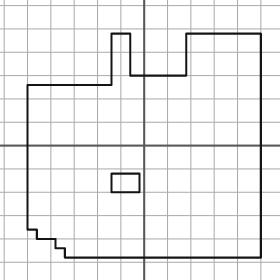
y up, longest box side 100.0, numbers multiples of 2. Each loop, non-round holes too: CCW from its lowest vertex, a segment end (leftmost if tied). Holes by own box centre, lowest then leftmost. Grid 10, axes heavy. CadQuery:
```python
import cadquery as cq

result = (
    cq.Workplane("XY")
    .moveTo(-34.0, -48.0)
    .lineTo(50.0, -48.0)
    .lineTo(50.0, 48.0)
    .lineTo(18.0, 48.0)
    .lineTo(18.0, 30.0)
    .lineTo(-6.0, 30.0)
    .lineTo(-6.0, 48.0)
    .lineTo(-14.0, 48.0)
    .lineTo(-14.0, 26.0)
    .lineTo(-50.0, 26.0)
    .lineTo(-50.0, -36.0)
    .lineTo(-46.0, -36.0)
    .lineTo(-46.0, -40.0)
    .lineTo(-38.0, -40.0)
    .lineTo(-38.0, -44.0)
    .lineTo(-34.0, -44.0)
    .close()
    .moveTo(-14.0, -20.0)
    .lineTo(-2.0, -20.0)
    .lineTo(-2.0, -12.0)
    .lineTo(-14.0, -12.0)
    .close()
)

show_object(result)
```